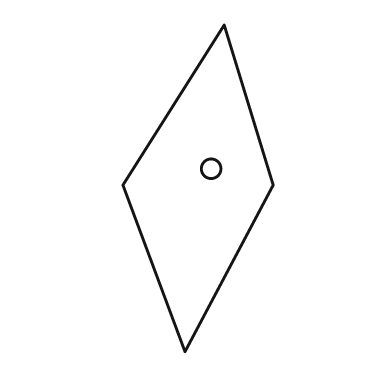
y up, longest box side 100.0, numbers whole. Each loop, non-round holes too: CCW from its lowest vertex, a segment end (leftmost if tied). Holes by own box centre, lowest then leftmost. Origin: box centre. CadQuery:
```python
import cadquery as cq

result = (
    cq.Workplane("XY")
    .moveTo(-4.0, -50.0)
    .lineTo(23.0, 1.0)
    .lineTo(8.0, 50.0)
    .lineTo(-23.0, 1.0)
    .close()
    .moveTo(4.0, 6.0)
    .circle(3.0)
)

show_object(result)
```